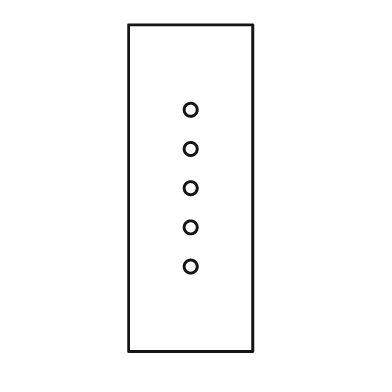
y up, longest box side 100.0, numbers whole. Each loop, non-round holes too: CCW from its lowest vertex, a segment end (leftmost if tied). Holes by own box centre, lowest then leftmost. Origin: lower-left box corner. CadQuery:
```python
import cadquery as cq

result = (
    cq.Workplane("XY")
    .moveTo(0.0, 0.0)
    .lineTo(38.0, 0.0)
    .lineTo(38.0, 100.0)
    .lineTo(0.0, 100.0)
    .close()
    .moveTo(19.0, 26.0)
    .circle(2.0)
    .moveTo(19.0, 38.0)
    .circle(2.0)
    .moveTo(19.0, 50.0)
    .circle(2.0)
    .moveTo(19.0, 62.0)
    .circle(2.0)
    .moveTo(19.0, 74.0)
    .circle(2.0)
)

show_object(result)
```